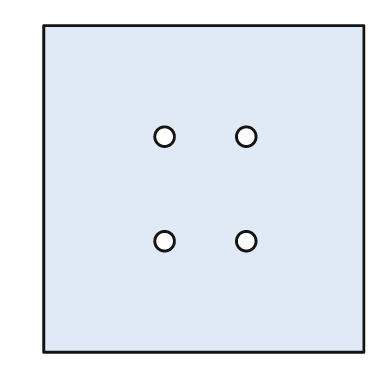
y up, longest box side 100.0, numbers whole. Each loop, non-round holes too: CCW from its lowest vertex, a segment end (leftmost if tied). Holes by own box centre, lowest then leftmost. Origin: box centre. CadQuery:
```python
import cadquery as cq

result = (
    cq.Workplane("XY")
    .moveTo(-49.0, -50.0)
    .lineTo(49.0, -50.0)
    .lineTo(49.0, 50.0)
    .lineTo(-49.0, 50.0)
    .close()
    .moveTo(-12.0, -16.0)
    .circle(3.0)
    .moveTo(13.0, -16.0)
    .circle(3.0)
    .moveTo(-12.0, 16.0)
    .circle(3.0)
    .moveTo(13.0, 16.0)
    .circle(3.0)
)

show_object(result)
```